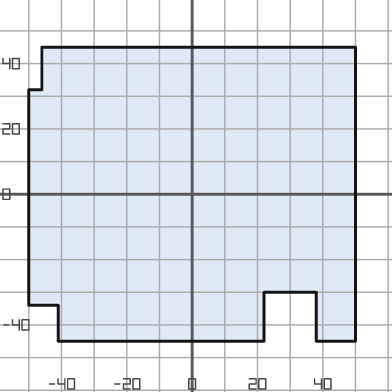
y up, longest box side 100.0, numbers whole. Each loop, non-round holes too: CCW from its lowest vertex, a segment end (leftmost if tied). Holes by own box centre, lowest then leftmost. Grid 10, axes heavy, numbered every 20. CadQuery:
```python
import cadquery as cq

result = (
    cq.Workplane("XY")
    .moveTo(-41.0, -45.0)
    .lineTo(22.0, -45.0)
    .lineTo(22.0, -30.0)
    .lineTo(38.0, -30.0)
    .lineTo(38.0, -45.0)
    .lineTo(50.0, -45.0)
    .lineTo(50.0, 45.0)
    .lineTo(-46.0, 45.0)
    .lineTo(-46.0, 32.0)
    .lineTo(-50.0, 32.0)
    .lineTo(-50.0, -34.0)
    .lineTo(-41.0, -34.0)
    .close()
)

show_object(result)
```